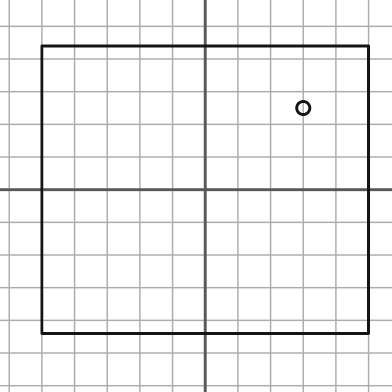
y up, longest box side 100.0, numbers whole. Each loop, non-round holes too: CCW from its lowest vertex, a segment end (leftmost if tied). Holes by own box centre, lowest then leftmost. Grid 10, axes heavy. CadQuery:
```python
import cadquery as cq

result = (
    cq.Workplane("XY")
    .moveTo(-50.0, -44.0)
    .lineTo(50.0, -44.0)
    .lineTo(50.0, 44.0)
    .lineTo(-50.0, 44.0)
    .close()
    .moveTo(30.0, 25.0)
    .circle(2.0)
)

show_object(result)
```